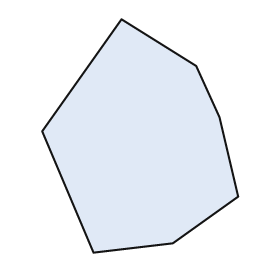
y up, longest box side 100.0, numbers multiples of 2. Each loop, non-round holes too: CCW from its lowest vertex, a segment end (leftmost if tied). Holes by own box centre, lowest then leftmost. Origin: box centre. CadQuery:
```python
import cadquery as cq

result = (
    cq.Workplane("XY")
    .moveTo(-20.0, -50.0)
    .lineTo(14.0, -46.0)
    .lineTo(42.0, -26.0)
    .lineTo(34.0, 8.0)
    .lineTo(24.0, 30.0)
    .lineTo(-8.0, 50.0)
    .lineTo(-42.0, 2.0)
    .close()
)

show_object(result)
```